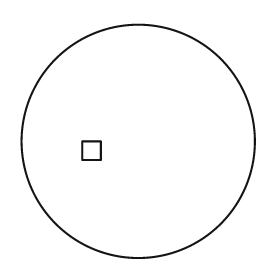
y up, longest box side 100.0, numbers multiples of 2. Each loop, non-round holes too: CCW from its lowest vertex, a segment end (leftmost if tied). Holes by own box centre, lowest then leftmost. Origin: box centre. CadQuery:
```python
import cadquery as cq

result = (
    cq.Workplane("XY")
    .moveTo(0.0, 0.0)
    .circle(50.0)
    .moveTo(-24.0, -8.0)
    .lineTo(-16.0, -8.0)
    .lineTo(-16.0, 0.0)
    .lineTo(-24.0, 0.0)
    .close()
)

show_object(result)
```